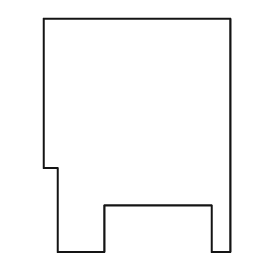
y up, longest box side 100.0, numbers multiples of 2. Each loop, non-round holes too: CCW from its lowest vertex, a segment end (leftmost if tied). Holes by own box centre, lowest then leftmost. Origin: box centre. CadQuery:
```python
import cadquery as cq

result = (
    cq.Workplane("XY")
    .moveTo(-34.0, -50.0)
    .lineTo(-14.0, -50.0)
    .lineTo(-14.0, -30.0)
    .lineTo(32.0, -30.0)
    .lineTo(32.0, -50.0)
    .lineTo(40.0, -50.0)
    .lineTo(40.0, 50.0)
    .lineTo(-40.0, 50.0)
    .lineTo(-40.0, -14.0)
    .lineTo(-34.0, -14.0)
    .close()
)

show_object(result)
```